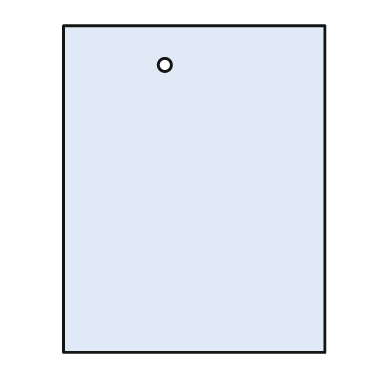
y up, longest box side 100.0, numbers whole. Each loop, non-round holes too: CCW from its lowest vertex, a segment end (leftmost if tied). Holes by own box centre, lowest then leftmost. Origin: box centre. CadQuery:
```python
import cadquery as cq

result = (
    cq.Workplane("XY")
    .moveTo(-40.0, -50.0)
    .lineTo(40.0, -50.0)
    .lineTo(40.0, 50.0)
    .lineTo(-40.0, 50.0)
    .close()
    .moveTo(-9.0, 38.0)
    .circle(2.0)
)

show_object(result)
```